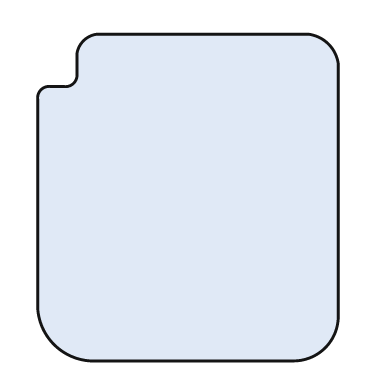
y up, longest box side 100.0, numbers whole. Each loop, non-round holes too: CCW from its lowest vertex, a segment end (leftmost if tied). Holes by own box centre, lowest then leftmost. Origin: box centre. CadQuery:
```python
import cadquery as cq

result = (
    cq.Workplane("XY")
    .moveTo(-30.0, -50.0)
    .lineTo(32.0, -50.0)
    .threePointArc((42.0, -46.0), (46.0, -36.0))
    .lineTo(46.0, 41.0)
    .threePointArc((43.0, 47.0), (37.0, 50.0))
    .lineTo(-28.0, 50.0)
    .threePointArc((-32.0, 48.0), (-34.0, 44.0))
    .lineTo(-34.0, 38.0)
    .threePointArc((-35.0, 35.0), (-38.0, 34.0))
    .lineTo(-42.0, 34.0)
    .threePointArc((-45.0, 33.0), (-46.0, 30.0))
    .lineTo(-46.0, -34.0)
    .threePointArc((-41.0, -45.0), (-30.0, -50.0))
    .close()
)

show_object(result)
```